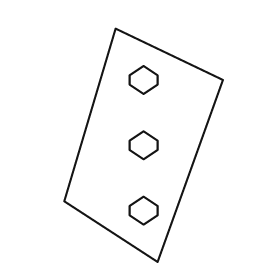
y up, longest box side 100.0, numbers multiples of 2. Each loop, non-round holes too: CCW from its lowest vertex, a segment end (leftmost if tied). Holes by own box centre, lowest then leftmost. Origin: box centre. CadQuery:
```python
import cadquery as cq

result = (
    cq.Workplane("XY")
    .moveTo(6.0, -50.0)
    .lineTo(34.0, 28.0)
    .lineTo(-12.0, 50.0)
    .lineTo(-34.0, -24.0)
    .close()
    .moveTo(0.0, -34.0)
    .lineTo(6.0, -30.0)
    .lineTo(6.0, -26.0)
    .lineTo(0.0, -22.0)
    .lineTo(-6.0, -26.0)
    .lineTo(-6.0, -30.0)
    .close()
    .moveTo(0.0, -6.0)
    .lineTo(6.0, -2.0)
    .lineTo(6.0, 2.0)
    .lineTo(0.0, 6.0)
    .lineTo(-6.0, 2.0)
    .lineTo(-6.0, -2.0)
    .close()
    .moveTo(0.0, 22.0)
    .lineTo(6.0, 26.0)
    .lineTo(6.0, 30.0)
    .lineTo(0.0, 34.0)
    .lineTo(-6.0, 30.0)
    .lineTo(-6.0, 26.0)
    .close()
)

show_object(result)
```